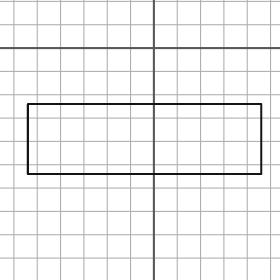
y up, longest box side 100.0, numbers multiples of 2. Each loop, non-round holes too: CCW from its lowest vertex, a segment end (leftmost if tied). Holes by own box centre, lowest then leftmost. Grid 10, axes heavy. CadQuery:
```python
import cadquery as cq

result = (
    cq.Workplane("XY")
    .moveTo(-54.0, -54.0)
    .lineTo(46.0, -54.0)
    .lineTo(46.0, -24.0)
    .lineTo(-54.0, -24.0)
    .close()
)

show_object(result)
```